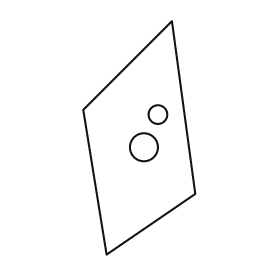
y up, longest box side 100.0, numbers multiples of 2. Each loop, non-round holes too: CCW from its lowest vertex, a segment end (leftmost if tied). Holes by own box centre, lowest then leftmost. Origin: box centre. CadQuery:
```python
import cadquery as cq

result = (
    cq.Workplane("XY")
    .moveTo(-14.0, -50.0)
    .lineTo(24.0, -24.0)
    .lineTo(14.0, 50.0)
    .lineTo(-24.0, 12.0)
    .close()
    .moveTo(2.0, -4.0)
    .circle(6.0)
    .moveTo(8.0, 10.0)
    .circle(4.0)
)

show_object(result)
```